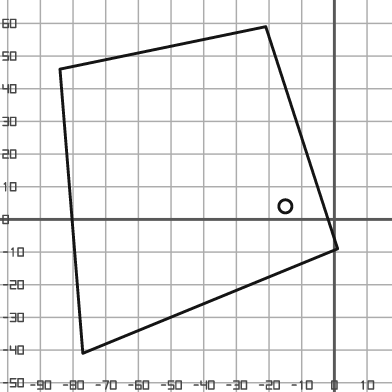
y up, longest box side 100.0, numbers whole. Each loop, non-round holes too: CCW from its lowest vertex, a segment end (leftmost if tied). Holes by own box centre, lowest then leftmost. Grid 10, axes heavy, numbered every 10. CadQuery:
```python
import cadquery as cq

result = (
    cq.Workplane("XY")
    .moveTo(-77.0, -41.0)
    .lineTo(1.0, -9.0)
    .lineTo(-21.0, 59.0)
    .lineTo(-84.0, 46.0)
    .close()
    .moveTo(-15.0, 4.0)
    .circle(2.0)
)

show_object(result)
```